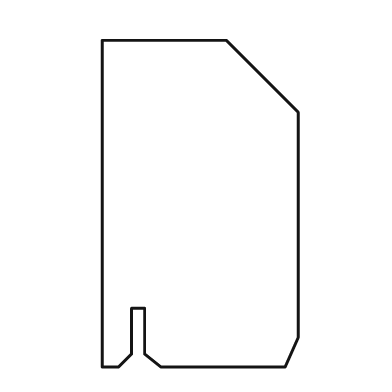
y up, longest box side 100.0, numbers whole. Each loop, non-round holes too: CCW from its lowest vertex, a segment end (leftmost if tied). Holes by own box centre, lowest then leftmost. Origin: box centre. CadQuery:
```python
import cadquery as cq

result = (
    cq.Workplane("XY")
    .moveTo(-30.0, -50.0)
    .lineTo(-25.0, -50.0)
    .lineTo(-21.0, -46.0)
    .lineTo(-21.0, -32.0)
    .lineTo(-17.0, -32.0)
    .lineTo(-17.0, -46.0)
    .lineTo(-12.0, -50.0)
    .lineTo(26.0, -50.0)
    .lineTo(30.0, -41.0)
    .lineTo(30.0, 28.0)
    .lineTo(8.0, 50.0)
    .lineTo(-30.0, 50.0)
    .close()
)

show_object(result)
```